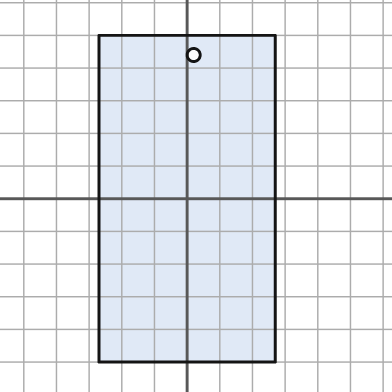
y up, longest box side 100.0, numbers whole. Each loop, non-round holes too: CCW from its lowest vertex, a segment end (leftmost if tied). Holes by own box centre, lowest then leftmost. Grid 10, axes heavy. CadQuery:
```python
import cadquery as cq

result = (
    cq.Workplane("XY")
    .moveTo(-27.0, -50.0)
    .lineTo(27.0, -50.0)
    .lineTo(27.0, 50.0)
    .lineTo(-27.0, 50.0)
    .close()
    .moveTo(2.0, 44.0)
    .circle(2.0)
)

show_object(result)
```